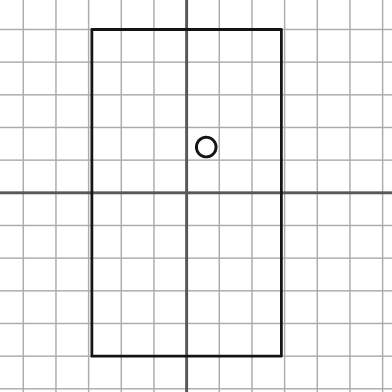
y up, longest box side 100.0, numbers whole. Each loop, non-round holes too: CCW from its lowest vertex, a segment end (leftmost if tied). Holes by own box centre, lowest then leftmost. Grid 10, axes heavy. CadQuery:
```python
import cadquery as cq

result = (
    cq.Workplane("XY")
    .moveTo(-29.0, -50.0)
    .lineTo(29.0, -50.0)
    .lineTo(29.0, 50.0)
    .lineTo(-29.0, 50.0)
    .close()
    .moveTo(6.0, 14.0)
    .circle(3.0)
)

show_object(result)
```